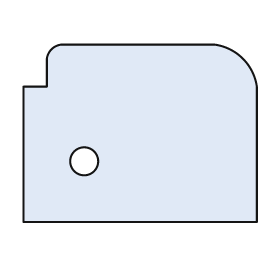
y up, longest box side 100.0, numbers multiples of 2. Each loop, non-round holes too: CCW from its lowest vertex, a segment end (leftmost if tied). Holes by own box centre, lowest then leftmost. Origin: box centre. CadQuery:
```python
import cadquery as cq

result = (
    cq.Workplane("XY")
    .moveTo(-50.0, -38.0)
    .lineTo(50.0, -38.0)
    .lineTo(50.0, 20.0)
    .threePointArc((44.0, 32.0), (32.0, 38.0))
    .lineTo(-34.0, 38.0)
    .threePointArc((-38.0, 36.0), (-40.0, 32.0))
    .lineTo(-40.0, 20.0)
    .lineTo(-50.0, 20.0)
    .close()
    .moveTo(-24.0, -12.0)
    .circle(6.0)
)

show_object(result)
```